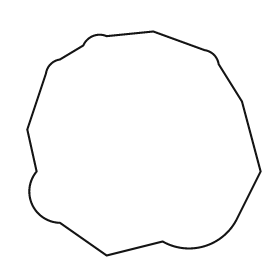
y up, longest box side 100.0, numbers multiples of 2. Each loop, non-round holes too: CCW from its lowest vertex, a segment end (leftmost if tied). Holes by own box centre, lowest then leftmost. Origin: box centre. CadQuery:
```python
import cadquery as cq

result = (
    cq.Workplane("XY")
    .moveTo(-16.0, -48.0)
    .lineTo(8.0, -42.0)
    .threePointArc((26.0, -44.0), (40.0, -32.0))
    .lineTo(50.0, -12.0)
    .lineTo(42.0, 18.0)
    .lineTo(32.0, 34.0)
    .threePointArc((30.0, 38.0), (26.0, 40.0))
    .lineTo(4.0, 48.0)
    .lineTo(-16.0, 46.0)
    .threePointArc((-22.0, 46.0), (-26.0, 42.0))
    .lineTo(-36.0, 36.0)
    .threePointArc((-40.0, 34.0), (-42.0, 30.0))
    .lineTo(-50.0, 6.0)
    .lineTo(-46.0, -12.0)
    .threePointArc((-48.0, -26.0), (-36.0, -34.0))
    .close()
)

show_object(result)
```